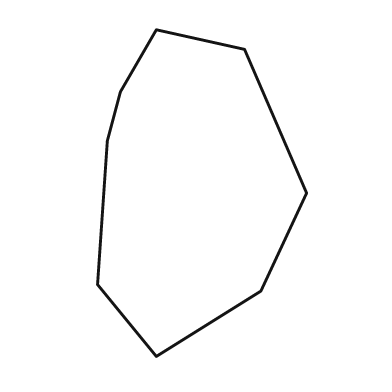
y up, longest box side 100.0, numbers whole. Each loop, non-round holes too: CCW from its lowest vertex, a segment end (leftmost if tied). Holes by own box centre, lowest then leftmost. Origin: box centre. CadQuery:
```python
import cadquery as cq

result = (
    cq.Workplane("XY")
    .moveTo(-14.0, -50.0)
    .lineTo(18.0, -30.0)
    .lineTo(32.0, 0.0)
    .lineTo(13.0, 44.0)
    .lineTo(-14.0, 50.0)
    .lineTo(-25.0, 31.0)
    .lineTo(-29.0, 16.0)
    .lineTo(-32.0, -28.0)
    .close()
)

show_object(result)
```